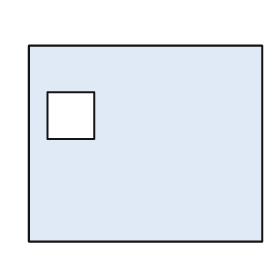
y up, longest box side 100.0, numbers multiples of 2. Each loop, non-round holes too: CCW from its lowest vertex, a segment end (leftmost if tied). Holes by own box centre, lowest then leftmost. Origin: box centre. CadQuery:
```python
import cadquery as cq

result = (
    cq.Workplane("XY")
    .moveTo(-50.0, -42.0)
    .lineTo(50.0, -42.0)
    .lineTo(50.0, 42.0)
    .lineTo(-50.0, 42.0)
    .close()
    .moveTo(-42.0, 2.0)
    .lineTo(-22.0, 2.0)
    .lineTo(-22.0, 22.0)
    .lineTo(-42.0, 22.0)
    .close()
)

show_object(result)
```